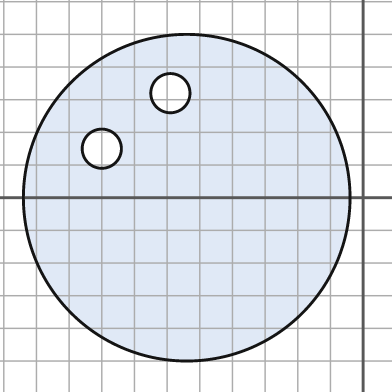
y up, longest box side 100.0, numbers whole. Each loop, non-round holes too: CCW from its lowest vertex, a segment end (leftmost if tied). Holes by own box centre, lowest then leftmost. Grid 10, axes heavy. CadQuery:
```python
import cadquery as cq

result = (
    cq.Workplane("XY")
    .moveTo(-54.0, 0.0)
    .circle(50.0)
    .moveTo(-80.0, 15.0)
    .circle(6.0)
    .moveTo(-59.0, 32.0)
    .circle(6.0)
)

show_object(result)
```